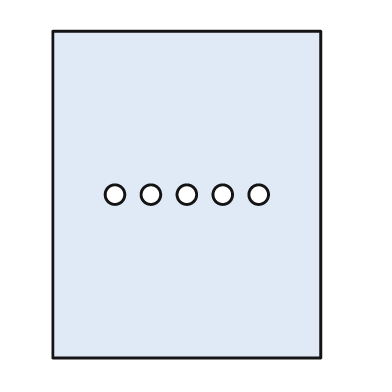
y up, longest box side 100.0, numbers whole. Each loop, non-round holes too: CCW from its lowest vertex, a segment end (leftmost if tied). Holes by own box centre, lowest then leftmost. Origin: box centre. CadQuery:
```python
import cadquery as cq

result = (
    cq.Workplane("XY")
    .moveTo(-41.0, -50.0)
    .lineTo(41.0, -50.0)
    .lineTo(41.0, 50.0)
    .lineTo(-41.0, 50.0)
    .close()
    .moveTo(-22.0, 0.0)
    .circle(3.0)
    .moveTo(-11.0, 0.0)
    .circle(3.0)
    .moveTo(0.0, 0.0)
    .circle(3.0)
    .moveTo(11.0, 0.0)
    .circle(3.0)
    .moveTo(22.0, 0.0)
    .circle(3.0)
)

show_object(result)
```